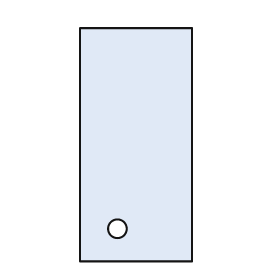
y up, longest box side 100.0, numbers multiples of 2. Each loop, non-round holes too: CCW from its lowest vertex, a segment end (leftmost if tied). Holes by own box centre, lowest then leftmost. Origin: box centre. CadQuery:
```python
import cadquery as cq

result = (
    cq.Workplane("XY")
    .moveTo(-24.0, -50.0)
    .lineTo(24.0, -50.0)
    .lineTo(24.0, 50.0)
    .lineTo(-24.0, 50.0)
    .close()
    .moveTo(-8.0, -36.0)
    .circle(4.0)
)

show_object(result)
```